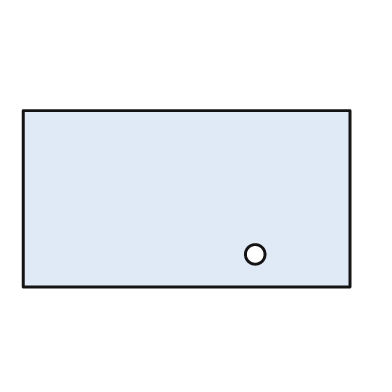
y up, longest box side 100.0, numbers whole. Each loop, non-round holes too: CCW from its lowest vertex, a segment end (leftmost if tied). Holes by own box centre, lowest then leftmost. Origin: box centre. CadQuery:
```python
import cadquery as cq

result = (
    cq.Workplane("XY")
    .moveTo(-50.0, -27.0)
    .lineTo(50.0, -27.0)
    .lineTo(50.0, 27.0)
    .lineTo(-50.0, 27.0)
    .close()
    .moveTo(21.0, -17.0)
    .circle(3.0)
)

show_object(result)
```